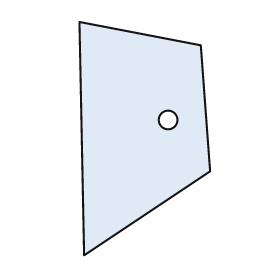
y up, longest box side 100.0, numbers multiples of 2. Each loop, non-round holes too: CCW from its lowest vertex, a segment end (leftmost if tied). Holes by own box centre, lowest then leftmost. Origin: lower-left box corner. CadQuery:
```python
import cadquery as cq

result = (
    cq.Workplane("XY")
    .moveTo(2.0, 0.0)
    .lineTo(56.0, 36.0)
    .lineTo(52.0, 90.0)
    .lineTo(0.0, 100.0)
    .close()
    .moveTo(38.0, 58.0)
    .circle(4.0)
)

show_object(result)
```